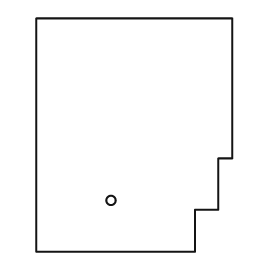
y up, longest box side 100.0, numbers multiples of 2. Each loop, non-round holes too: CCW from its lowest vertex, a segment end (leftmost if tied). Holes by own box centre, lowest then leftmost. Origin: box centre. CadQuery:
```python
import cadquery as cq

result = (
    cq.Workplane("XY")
    .moveTo(-42.0, -50.0)
    .lineTo(26.0, -50.0)
    .lineTo(26.0, -32.0)
    .lineTo(36.0, -32.0)
    .lineTo(36.0, -10.0)
    .lineTo(42.0, -10.0)
    .lineTo(42.0, 50.0)
    .lineTo(-42.0, 50.0)
    .close()
    .moveTo(-10.0, -28.0)
    .circle(2.0)
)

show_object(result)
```